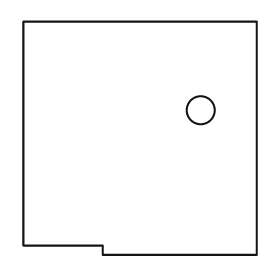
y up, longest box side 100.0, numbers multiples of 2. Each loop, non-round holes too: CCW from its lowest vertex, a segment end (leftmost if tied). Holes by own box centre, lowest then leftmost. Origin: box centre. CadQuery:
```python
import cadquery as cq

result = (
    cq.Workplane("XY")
    .moveTo(-16.0, -50.0)
    .lineTo(50.0, -50.0)
    .lineTo(50.0, 50.0)
    .lineTo(-50.0, 50.0)
    .lineTo(-50.0, -46.0)
    .lineTo(-16.0, -46.0)
    .close()
    .moveTo(26.0, 12.0)
    .circle(6.0)
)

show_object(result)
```